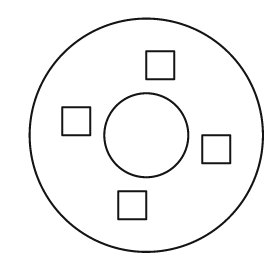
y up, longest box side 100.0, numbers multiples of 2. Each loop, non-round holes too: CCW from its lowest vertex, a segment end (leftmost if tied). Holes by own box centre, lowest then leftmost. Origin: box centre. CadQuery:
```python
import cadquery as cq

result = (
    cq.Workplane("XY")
    .moveTo(0.0, 0.0)
    .circle(50.0)
    .moveTo(-12.0, -36.0)
    .lineTo(0.0, -36.0)
    .lineTo(0.0, -24.0)
    .lineTo(-12.0, -24.0)
    .close()
    .moveTo(24.0, -12.0)
    .lineTo(36.0, -12.0)
    .lineTo(36.0, 0.0)
    .lineTo(24.0, 0.0)
    .close()
    .moveTo(0.0, 0.0)
    .circle(18.0)
    .moveTo(-36.0, 0.0)
    .lineTo(-24.0, 0.0)
    .lineTo(-24.0, 12.0)
    .lineTo(-36.0, 12.0)
    .close()
    .moveTo(0.0, 24.0)
    .lineTo(12.0, 24.0)
    .lineTo(12.0, 36.0)
    .lineTo(0.0, 36.0)
    .close()
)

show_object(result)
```